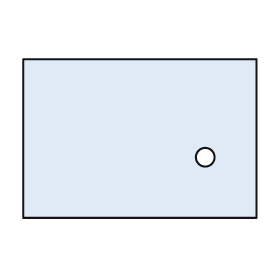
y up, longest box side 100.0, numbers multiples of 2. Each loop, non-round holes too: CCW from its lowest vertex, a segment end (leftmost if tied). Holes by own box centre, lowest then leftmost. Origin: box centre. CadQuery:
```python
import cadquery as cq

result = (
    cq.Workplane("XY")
    .moveTo(-50.0, -34.0)
    .lineTo(50.0, -34.0)
    .lineTo(50.0, 34.0)
    .lineTo(-50.0, 34.0)
    .close()
    .moveTo(28.0, -8.0)
    .circle(4.0)
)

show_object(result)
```